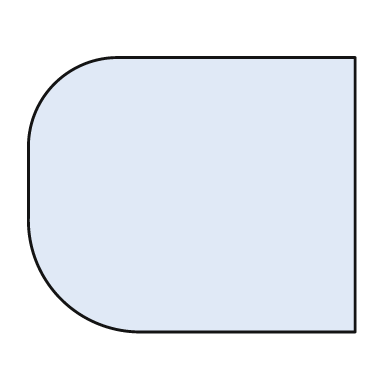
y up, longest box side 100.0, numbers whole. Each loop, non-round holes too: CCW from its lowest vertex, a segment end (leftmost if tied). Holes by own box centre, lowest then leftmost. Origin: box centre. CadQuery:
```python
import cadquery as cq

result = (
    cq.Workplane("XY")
    .moveTo(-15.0, -42.0)
    .lineTo(50.0, -42.0)
    .lineTo(50.0, 42.0)
    .lineTo(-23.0, 42.0)
    .threePointArc((-42.0, 34.0), (-50.0, 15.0))
    .lineTo(-50.0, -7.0)
    .threePointArc((-40.0, -32.0), (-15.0, -42.0))
    .close()
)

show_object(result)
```